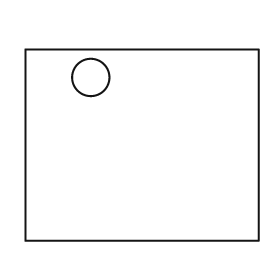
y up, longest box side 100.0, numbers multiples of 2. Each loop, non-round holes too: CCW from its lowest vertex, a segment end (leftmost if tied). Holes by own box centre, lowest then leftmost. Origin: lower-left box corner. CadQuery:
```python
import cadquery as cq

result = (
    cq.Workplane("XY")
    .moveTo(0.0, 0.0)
    .lineTo(100.0, 0.0)
    .lineTo(100.0, 82.0)
    .lineTo(0.0, 82.0)
    .close()
    .moveTo(28.0, 70.0)
    .circle(8.0)
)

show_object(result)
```